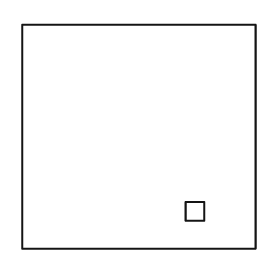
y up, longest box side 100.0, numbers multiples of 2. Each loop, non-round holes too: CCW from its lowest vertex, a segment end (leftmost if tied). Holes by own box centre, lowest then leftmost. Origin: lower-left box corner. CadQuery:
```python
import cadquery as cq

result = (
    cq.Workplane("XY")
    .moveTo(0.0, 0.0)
    .lineTo(100.0, 0.0)
    .lineTo(100.0, 96.0)
    .lineTo(0.0, 96.0)
    .close()
    .moveTo(70.0, 12.0)
    .lineTo(78.0, 12.0)
    .lineTo(78.0, 20.0)
    .lineTo(70.0, 20.0)
    .close()
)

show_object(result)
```